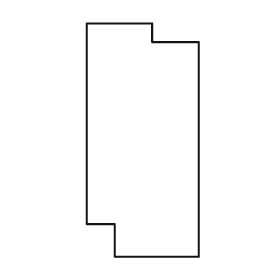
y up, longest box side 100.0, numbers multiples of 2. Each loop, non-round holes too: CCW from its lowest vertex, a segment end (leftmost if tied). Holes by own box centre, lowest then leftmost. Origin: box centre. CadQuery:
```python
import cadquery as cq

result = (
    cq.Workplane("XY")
    .moveTo(-12.0, -50.0)
    .lineTo(24.0, -50.0)
    .lineTo(24.0, 42.0)
    .lineTo(4.0, 42.0)
    .lineTo(4.0, 50.0)
    .lineTo(-24.0, 50.0)
    .lineTo(-24.0, -36.0)
    .lineTo(-12.0, -36.0)
    .close()
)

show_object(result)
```